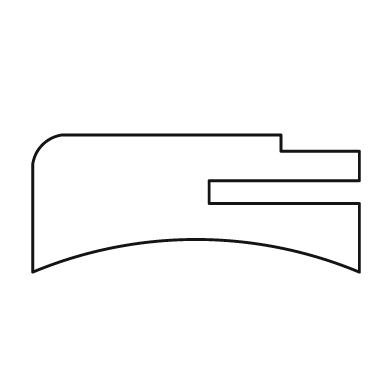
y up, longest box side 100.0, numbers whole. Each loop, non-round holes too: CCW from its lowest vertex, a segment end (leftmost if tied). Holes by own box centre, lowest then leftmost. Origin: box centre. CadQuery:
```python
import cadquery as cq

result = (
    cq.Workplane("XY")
    .moveTo(-50.0, -21.0)
    .threePointArc((0.0, -11.0), (50.0, -21.0))
    .lineTo(50.0, 0.0)
    .lineTo(4.0, 0.0)
    .lineTo(4.0, 7.0)
    .lineTo(50.0, 7.0)
    .lineTo(50.0, 16.0)
    .lineTo(26.0, 16.0)
    .lineTo(26.0, 21.0)
    .lineTo(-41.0, 21.0)
    .threePointArc((-47.0, 18.0), (-50.0, 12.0))
    .close()
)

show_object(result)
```